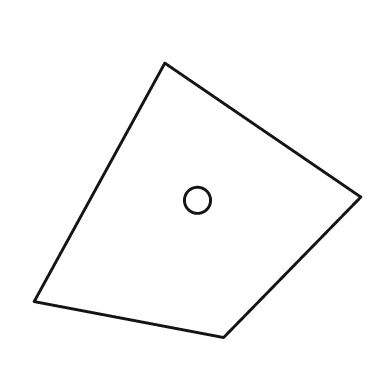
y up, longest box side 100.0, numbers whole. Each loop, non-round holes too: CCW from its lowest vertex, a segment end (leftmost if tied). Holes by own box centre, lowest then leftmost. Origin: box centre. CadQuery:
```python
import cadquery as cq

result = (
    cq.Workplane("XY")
    .moveTo(8.0, -42.0)
    .lineTo(50.0, 1.0)
    .lineTo(-10.0, 42.0)
    .lineTo(-50.0, -31.0)
    .close()
    .moveTo(0.0, 0.0)
    .circle(4.0)
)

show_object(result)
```